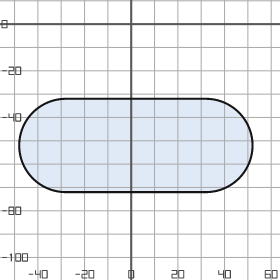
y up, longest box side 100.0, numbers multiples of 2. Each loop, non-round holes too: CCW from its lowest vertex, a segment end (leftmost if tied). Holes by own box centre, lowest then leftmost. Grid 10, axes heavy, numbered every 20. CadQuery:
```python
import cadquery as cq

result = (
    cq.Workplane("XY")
    .moveTo(-28.0, -72.0)
    .lineTo(32.0, -72.0)
    .threePointArc((52.0, -52.0), (32.0, -32.0))
    .lineTo(-28.0, -32.0)
    .threePointArc((-48.0, -52.0), (-28.0, -72.0))
    .close()
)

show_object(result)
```